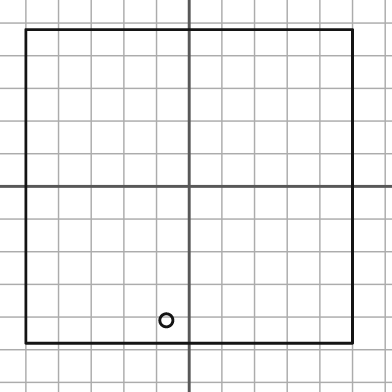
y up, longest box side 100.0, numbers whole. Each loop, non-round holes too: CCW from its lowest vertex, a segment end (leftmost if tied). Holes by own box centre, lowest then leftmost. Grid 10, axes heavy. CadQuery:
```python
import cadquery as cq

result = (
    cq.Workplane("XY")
    .moveTo(-50.0, -48.0)
    .lineTo(50.0, -48.0)
    .lineTo(50.0, 48.0)
    .lineTo(-50.0, 48.0)
    .close()
    .moveTo(-7.0, -41.0)
    .circle(2.0)
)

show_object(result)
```